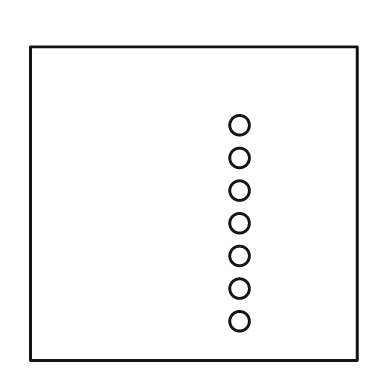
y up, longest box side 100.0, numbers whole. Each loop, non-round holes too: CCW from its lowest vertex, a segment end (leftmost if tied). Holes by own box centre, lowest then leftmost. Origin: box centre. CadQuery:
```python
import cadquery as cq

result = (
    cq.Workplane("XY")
    .moveTo(-50.0, -48.0)
    .lineTo(50.0, -48.0)
    .lineTo(50.0, 48.0)
    .lineTo(-50.0, 48.0)
    .close()
    .moveTo(14.0, -36.0)
    .circle(3.0)
    .moveTo(14.0, -26.0)
    .circle(3.0)
    .moveTo(14.0, -16.0)
    .circle(3.0)
    .moveTo(14.0, -6.0)
    .circle(3.0)
    .moveTo(14.0, 4.0)
    .circle(3.0)
    .moveTo(14.0, 14.0)
    .circle(3.0)
    .moveTo(14.0, 24.0)
    .circle(3.0)
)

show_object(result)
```